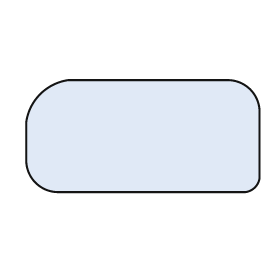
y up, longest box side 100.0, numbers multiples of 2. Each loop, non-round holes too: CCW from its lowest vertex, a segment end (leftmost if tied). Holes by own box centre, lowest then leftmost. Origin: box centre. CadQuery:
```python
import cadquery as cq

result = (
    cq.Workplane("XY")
    .moveTo(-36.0, -24.0)
    .lineTo(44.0, -24.0)
    .threePointArc((48.0, -22.0), (50.0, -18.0))
    .lineTo(50.0, 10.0)
    .threePointArc((46.0, 20.0), (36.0, 24.0))
    .lineTo(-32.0, 24.0)
    .threePointArc((-44.0, 18.0), (-50.0, 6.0))
    .lineTo(-50.0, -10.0)
    .threePointArc((-46.0, -20.0), (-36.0, -24.0))
    .close()
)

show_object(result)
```